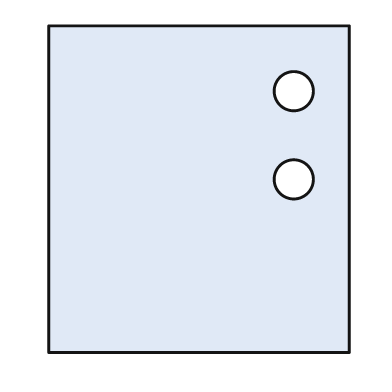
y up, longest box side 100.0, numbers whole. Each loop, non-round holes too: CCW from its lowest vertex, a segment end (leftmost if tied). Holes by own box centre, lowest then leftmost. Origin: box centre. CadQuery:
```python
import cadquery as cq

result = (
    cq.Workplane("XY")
    .moveTo(-46.0, -50.0)
    .lineTo(46.0, -50.0)
    .lineTo(46.0, 50.0)
    .lineTo(-46.0, 50.0)
    .close()
    .moveTo(29.0, 3.0)
    .circle(6.0)
    .moveTo(29.0, 30.0)
    .circle(6.0)
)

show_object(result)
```